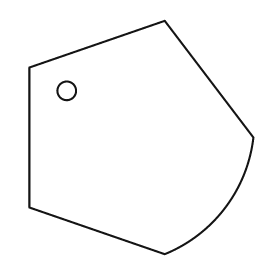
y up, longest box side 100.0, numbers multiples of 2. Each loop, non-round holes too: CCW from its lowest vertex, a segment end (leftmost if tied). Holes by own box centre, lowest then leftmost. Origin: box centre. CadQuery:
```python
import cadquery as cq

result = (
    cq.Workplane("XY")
    .moveTo(10.0, -50.0)
    .threePointArc((36.0, -30.0), (48.0, 0.0))
    .lineTo(10.0, 50.0)
    .lineTo(-48.0, 30.0)
    .lineTo(-48.0, -30.0)
    .close()
    .moveTo(-32.0, 20.0)
    .circle(4.0)
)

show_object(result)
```